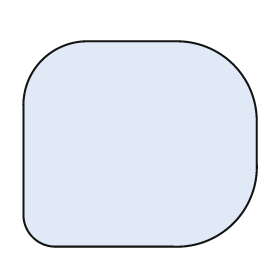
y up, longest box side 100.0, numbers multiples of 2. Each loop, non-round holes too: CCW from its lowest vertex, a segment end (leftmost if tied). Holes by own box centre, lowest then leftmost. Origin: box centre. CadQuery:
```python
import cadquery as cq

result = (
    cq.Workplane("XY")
    .moveTo(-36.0, -44.0)
    .lineTo(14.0, -44.0)
    .threePointArc((40.0, -34.0), (50.0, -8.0))
    .lineTo(50.0, 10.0)
    .threePointArc((40.0, 34.0), (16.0, 44.0))
    .lineTo(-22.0, 44.0)
    .threePointArc((-42.0, 36.0), (-50.0, 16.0))
    .lineTo(-50.0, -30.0)
    .threePointArc((-46.0, -40.0), (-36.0, -44.0))
    .close()
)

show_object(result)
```